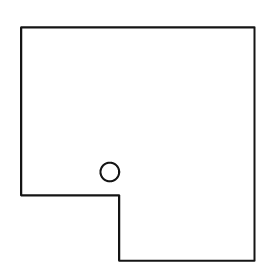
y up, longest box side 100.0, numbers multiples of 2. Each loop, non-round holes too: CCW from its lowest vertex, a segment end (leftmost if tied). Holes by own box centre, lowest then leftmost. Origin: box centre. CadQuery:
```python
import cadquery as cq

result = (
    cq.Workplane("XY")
    .moveTo(-8.0, -50.0)
    .lineTo(50.0, -50.0)
    .lineTo(50.0, 50.0)
    .lineTo(-50.0, 50.0)
    .lineTo(-50.0, -22.0)
    .lineTo(-8.0, -22.0)
    .close()
    .moveTo(-12.0, -12.0)
    .circle(4.0)
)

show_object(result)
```